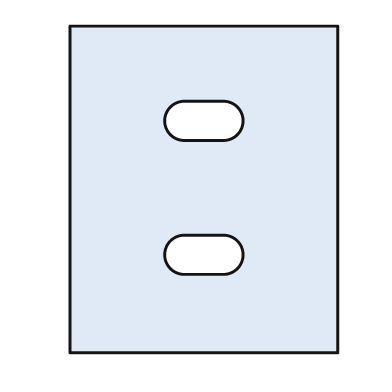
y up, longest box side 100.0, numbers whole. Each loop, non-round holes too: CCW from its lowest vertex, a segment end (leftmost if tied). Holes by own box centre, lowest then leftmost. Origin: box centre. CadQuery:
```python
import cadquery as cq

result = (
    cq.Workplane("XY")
    .moveTo(-41.0, -50.0)
    .lineTo(41.0, -50.0)
    .lineTo(41.0, 50.0)
    .lineTo(-41.0, 50.0)
    .close()
    .moveTo(-6.0, -26.0)
    .lineTo(6.0, -26.0)
    .threePointArc((12.0, -20.0), (6.0, -14.0))
    .lineTo(-6.0, -14.0)
    .threePointArc((-12.0, -20.0), (-6.0, -26.0))
    .close()
    .moveTo(-6.0, 15.0)
    .lineTo(6.0, 15.0)
    .threePointArc((12.0, 21.0), (6.0, 27.0))
    .lineTo(-6.0, 27.0)
    .threePointArc((-12.0, 21.0), (-6.0, 15.0))
    .close()
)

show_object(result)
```